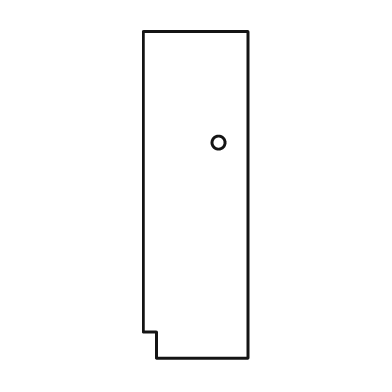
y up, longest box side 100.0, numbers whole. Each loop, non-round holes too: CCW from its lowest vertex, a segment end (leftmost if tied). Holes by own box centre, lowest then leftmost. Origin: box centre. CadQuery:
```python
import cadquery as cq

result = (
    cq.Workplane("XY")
    .moveTo(-12.0, -50.0)
    .lineTo(16.0, -50.0)
    .lineTo(16.0, 50.0)
    .lineTo(-16.0, 50.0)
    .lineTo(-16.0, -42.0)
    .lineTo(-12.0, -42.0)
    .close()
    .moveTo(7.0, 16.0)
    .circle(2.0)
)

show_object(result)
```